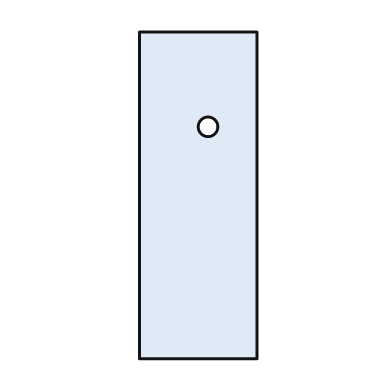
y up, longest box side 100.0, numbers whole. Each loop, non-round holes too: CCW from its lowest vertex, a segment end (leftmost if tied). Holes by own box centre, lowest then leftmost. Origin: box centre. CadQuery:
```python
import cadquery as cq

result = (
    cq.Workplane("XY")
    .moveTo(-18.0, -50.0)
    .lineTo(18.0, -50.0)
    .lineTo(18.0, 50.0)
    .lineTo(-18.0, 50.0)
    .close()
    .moveTo(3.0, 21.0)
    .circle(3.0)
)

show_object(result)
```